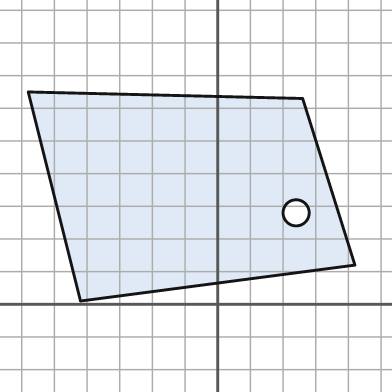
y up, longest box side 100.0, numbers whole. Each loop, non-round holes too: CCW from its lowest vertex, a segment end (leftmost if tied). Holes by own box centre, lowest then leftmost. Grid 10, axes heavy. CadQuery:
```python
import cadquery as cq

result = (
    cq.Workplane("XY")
    .moveTo(-42.0, 1.0)
    .lineTo(42.0, 12.0)
    .lineTo(26.0, 63.0)
    .lineTo(-58.0, 65.0)
    .close()
    .moveTo(24.0, 28.0)
    .circle(4.0)
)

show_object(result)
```